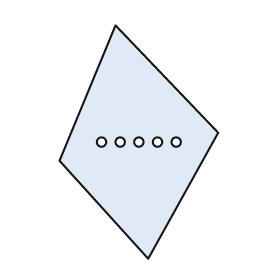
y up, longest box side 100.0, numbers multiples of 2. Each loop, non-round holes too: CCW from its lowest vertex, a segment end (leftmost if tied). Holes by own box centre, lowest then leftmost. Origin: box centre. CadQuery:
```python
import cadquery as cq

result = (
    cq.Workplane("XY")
    .moveTo(4.0, -50.0)
    .lineTo(34.0, 4.0)
    .lineTo(-10.0, 50.0)
    .lineTo(-34.0, -8.0)
    .close()
    .moveTo(-16.0, 0.0)
    .circle(2.0)
    .moveTo(-8.0, 0.0)
    .circle(2.0)
    .moveTo(0.0, 0.0)
    .circle(2.0)
    .moveTo(8.0, 0.0)
    .circle(2.0)
    .moveTo(16.0, 0.0)
    .circle(2.0)
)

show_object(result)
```